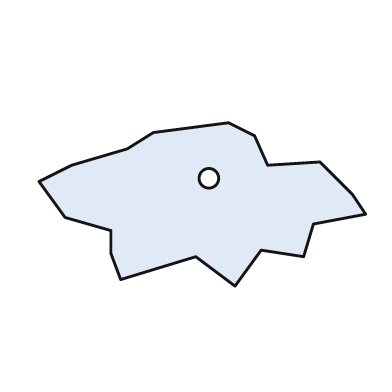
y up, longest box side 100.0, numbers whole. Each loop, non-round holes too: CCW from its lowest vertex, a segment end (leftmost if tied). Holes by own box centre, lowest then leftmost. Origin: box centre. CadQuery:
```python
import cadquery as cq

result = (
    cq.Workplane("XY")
    .moveTo(10.0, -25.0)
    .lineTo(18.0, -14.0)
    .lineTo(31.0, -16.0)
    .lineTo(34.0, -6.0)
    .lineTo(50.0, -3.0)
    .lineTo(46.0, 3.0)
    .lineTo(36.0, 13.0)
    .lineTo(20.0, 12.0)
    .lineTo(16.0, 21.0)
    .lineTo(8.0, 25.0)
    .lineTo(-15.0, 22.0)
    .lineTo(-23.0, 17.0)
    .lineTo(-40.0, 12.0)
    .lineTo(-50.0, 7.0)
    .lineTo(-42.0, -4.0)
    .lineTo(-28.0, -8.0)
    .lineTo(-28.0, -15.0)
    .lineTo(-25.0, -23.0)
    .lineTo(-2.0, -16.0)
    .close()
    .moveTo(2.0, 8.0)
    .circle(3.0)
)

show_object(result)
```